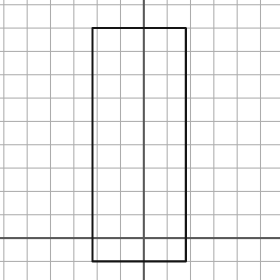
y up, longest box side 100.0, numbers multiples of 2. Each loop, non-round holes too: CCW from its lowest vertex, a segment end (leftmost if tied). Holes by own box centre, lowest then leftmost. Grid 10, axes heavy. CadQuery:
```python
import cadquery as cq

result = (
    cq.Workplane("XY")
    .moveTo(-22.0, -10.0)
    .lineTo(18.0, -10.0)
    .lineTo(18.0, 90.0)
    .lineTo(-22.0, 90.0)
    .close()
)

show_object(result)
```